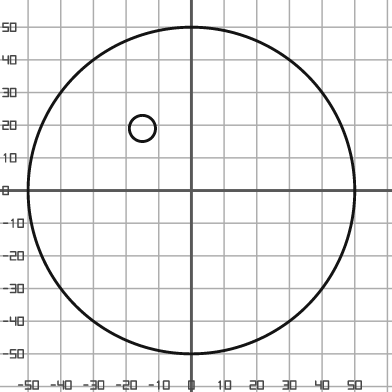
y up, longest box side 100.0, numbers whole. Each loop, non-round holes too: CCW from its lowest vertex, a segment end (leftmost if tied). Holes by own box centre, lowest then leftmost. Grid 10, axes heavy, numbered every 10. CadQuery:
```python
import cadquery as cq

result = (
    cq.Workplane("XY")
    .moveTo(0.0, 0.0)
    .circle(50.0)
    .moveTo(-15.0, 19.0)
    .circle(4.0)
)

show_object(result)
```